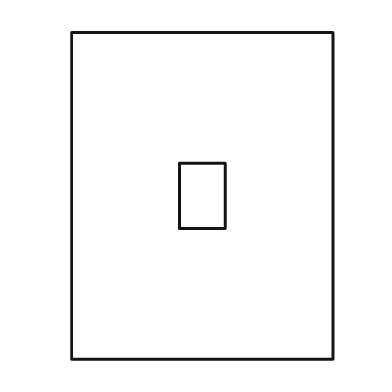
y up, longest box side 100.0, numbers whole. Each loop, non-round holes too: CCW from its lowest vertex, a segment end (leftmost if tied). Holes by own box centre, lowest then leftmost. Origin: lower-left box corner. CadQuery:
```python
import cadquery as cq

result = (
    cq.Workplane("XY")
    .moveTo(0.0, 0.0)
    .lineTo(80.0, 0.0)
    .lineTo(80.0, 100.0)
    .lineTo(0.0, 100.0)
    .close()
    .moveTo(33.0, 40.0)
    .lineTo(47.0, 40.0)
    .lineTo(47.0, 60.0)
    .lineTo(33.0, 60.0)
    .close()
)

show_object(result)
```